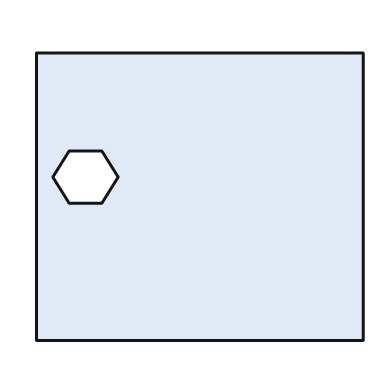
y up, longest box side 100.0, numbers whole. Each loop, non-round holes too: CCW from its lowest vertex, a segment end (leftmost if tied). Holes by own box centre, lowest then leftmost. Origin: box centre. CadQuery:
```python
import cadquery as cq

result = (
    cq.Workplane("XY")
    .moveTo(-50.0, -44.0)
    .lineTo(50.0, -44.0)
    .lineTo(50.0, 44.0)
    .lineTo(-50.0, 44.0)
    .close()
    .moveTo(-40.0, -2.0)
    .lineTo(-30.0, -2.0)
    .lineTo(-25.0, 6.0)
    .lineTo(-30.0, 14.0)
    .lineTo(-40.0, 14.0)
    .lineTo(-45.0, 6.0)
    .close()
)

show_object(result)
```